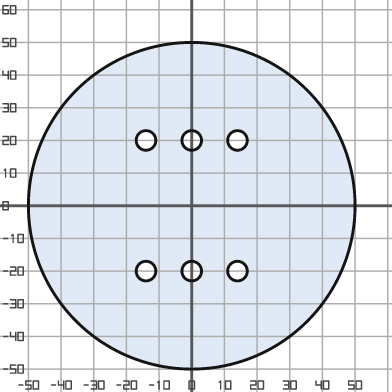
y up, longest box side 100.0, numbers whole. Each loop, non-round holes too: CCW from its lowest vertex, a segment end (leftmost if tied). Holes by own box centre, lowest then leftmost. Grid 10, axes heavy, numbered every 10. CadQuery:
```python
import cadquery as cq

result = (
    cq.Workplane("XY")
    .moveTo(0.0, 0.0)
    .circle(50.0)
    .moveTo(-14.0, -20.0)
    .circle(3.0)
    .moveTo(0.0, -20.0)
    .circle(3.0)
    .moveTo(14.0, -20.0)
    .circle(3.0)
    .moveTo(-14.0, 20.0)
    .circle(3.0)
    .moveTo(0.0, 20.0)
    .circle(3.0)
    .moveTo(14.0, 20.0)
    .circle(3.0)
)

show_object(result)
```